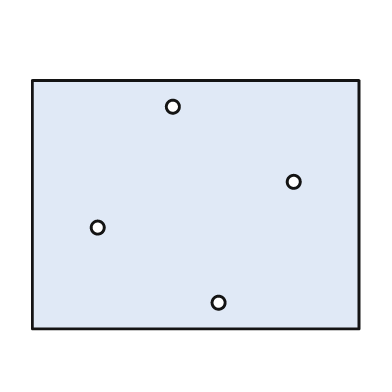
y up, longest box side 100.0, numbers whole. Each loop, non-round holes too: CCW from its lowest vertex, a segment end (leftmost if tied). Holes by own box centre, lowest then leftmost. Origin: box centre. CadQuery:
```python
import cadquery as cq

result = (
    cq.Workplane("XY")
    .moveTo(-50.0, -38.0)
    .lineTo(50.0, -38.0)
    .lineTo(50.0, 38.0)
    .lineTo(-50.0, 38.0)
    .close()
    .moveTo(7.0, -30.0)
    .circle(2.0)
    .moveTo(-30.0, -7.0)
    .circle(2.0)
    .moveTo(30.0, 7.0)
    .circle(2.0)
    .moveTo(-7.0, 30.0)
    .circle(2.0)
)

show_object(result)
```